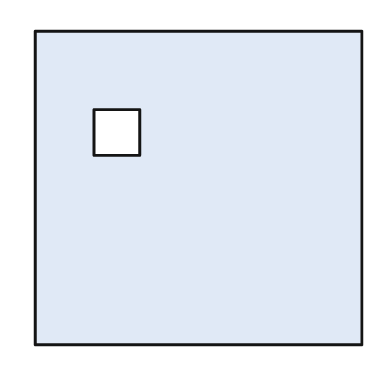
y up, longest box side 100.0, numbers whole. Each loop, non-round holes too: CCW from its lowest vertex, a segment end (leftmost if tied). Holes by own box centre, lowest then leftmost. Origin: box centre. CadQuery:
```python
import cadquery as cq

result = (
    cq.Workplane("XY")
    .moveTo(-50.0, -48.0)
    .lineTo(50.0, -48.0)
    .lineTo(50.0, 48.0)
    .lineTo(-50.0, 48.0)
    .close()
    .moveTo(-32.0, 10.0)
    .lineTo(-18.0, 10.0)
    .lineTo(-18.0, 24.0)
    .lineTo(-32.0, 24.0)
    .close()
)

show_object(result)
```